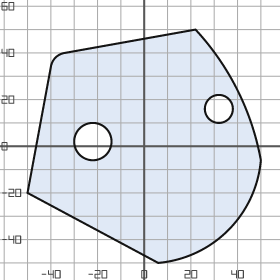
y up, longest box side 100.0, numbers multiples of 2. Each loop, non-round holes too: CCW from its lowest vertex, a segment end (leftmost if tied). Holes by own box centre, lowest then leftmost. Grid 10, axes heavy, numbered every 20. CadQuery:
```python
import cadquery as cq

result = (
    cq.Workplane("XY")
    .moveTo(6.0, -50.0)
    .threePointArc((36.0, -36.0), (50.0, -6.0))
    .threePointArc((40.0, 24.0), (22.0, 50.0))
    .lineTo(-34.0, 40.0)
    .threePointArc((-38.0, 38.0), (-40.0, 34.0))
    .lineTo(-50.0, -20.0)
    .close()
    .moveTo(-22.0, 2.0)
    .circle(8.0)
    .moveTo(32.0, 16.0)
    .circle(6.0)
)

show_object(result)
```